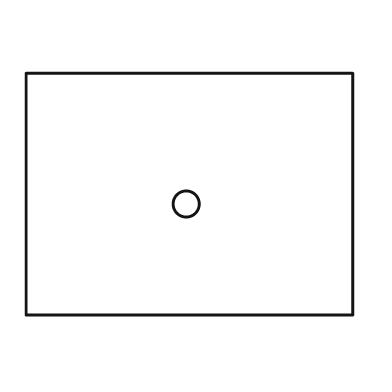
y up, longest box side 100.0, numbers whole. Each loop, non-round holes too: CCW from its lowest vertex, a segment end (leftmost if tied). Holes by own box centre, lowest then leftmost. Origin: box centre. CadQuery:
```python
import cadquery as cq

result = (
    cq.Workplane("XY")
    .moveTo(-50.0, -37.0)
    .lineTo(50.0, -37.0)
    .lineTo(50.0, 37.0)
    .lineTo(-50.0, 37.0)
    .close()
    .moveTo(-1.0, -3.0)
    .circle(4.0)
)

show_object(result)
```